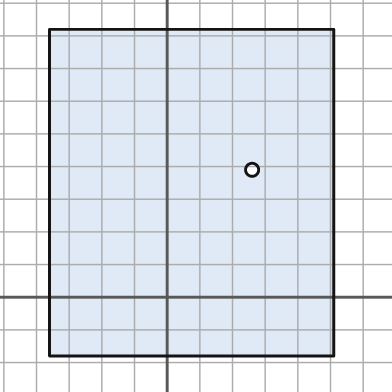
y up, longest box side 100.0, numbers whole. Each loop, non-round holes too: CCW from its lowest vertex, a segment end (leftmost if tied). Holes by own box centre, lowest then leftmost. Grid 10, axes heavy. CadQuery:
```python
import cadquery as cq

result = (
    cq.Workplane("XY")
    .moveTo(-36.0, -18.0)
    .lineTo(51.0, -18.0)
    .lineTo(51.0, 82.0)
    .lineTo(-36.0, 82.0)
    .close()
    .moveTo(26.0, 39.0)
    .circle(2.0)
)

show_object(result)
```